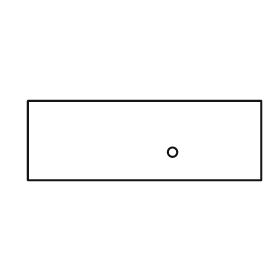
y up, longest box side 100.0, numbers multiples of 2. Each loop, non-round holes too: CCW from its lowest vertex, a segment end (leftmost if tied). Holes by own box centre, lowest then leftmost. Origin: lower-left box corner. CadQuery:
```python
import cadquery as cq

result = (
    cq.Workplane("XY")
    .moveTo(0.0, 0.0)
    .lineTo(100.0, 0.0)
    .lineTo(100.0, 34.0)
    .lineTo(0.0, 34.0)
    .close()
    .moveTo(62.0, 12.0)
    .circle(2.0)
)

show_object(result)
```